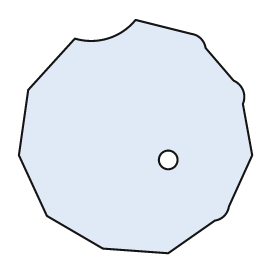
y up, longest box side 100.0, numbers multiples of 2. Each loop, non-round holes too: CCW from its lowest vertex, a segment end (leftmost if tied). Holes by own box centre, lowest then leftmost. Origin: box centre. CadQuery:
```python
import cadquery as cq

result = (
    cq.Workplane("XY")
    .moveTo(14.0, -50.0)
    .lineTo(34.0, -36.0)
    .threePointArc((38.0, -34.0), (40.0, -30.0))
    .lineTo(50.0, -8.0)
    .lineTo(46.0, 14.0)
    .threePointArc((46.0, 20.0), (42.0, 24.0))
    .lineTo(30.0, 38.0)
    .threePointArc((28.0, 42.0), (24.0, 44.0))
    .lineTo(0.0, 50.0)
    .threePointArc((-12.0, 42.0), (-26.0, 42.0))
    .lineTo(-46.0, 20.0)
    .lineTo(-50.0, -8.0)
    .lineTo(-38.0, -34.0)
    .lineTo(-14.0, -48.0)
    .close()
    .moveTo(14.0, -10.0)
    .circle(4.0)
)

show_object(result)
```